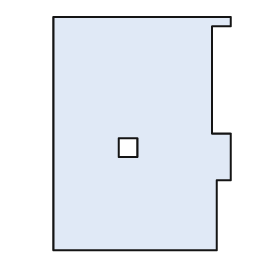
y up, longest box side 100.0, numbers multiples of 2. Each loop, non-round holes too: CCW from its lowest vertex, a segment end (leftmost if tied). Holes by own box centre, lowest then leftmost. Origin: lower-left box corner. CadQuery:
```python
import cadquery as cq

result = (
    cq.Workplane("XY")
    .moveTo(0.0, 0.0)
    .lineTo(70.0, 0.0)
    .lineTo(70.0, 30.0)
    .lineTo(76.0, 30.0)
    .lineTo(76.0, 50.0)
    .lineTo(68.0, 50.0)
    .lineTo(68.0, 96.0)
    .lineTo(76.0, 96.0)
    .lineTo(76.0, 100.0)
    .lineTo(0.0, 100.0)
    .close()
    .moveTo(28.0, 40.0)
    .lineTo(36.0, 40.0)
    .lineTo(36.0, 48.0)
    .lineTo(28.0, 48.0)
    .close()
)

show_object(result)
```